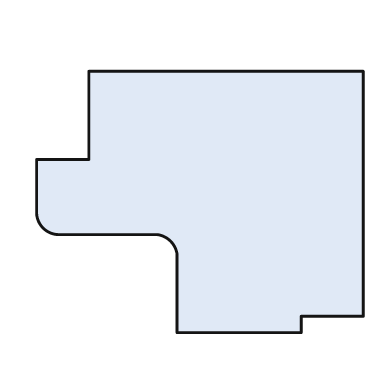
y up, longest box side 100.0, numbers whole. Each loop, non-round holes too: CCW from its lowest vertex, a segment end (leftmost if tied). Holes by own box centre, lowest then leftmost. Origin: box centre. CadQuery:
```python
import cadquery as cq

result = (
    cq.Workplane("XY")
    .moveTo(-7.0, -40.0)
    .lineTo(31.0, -40.0)
    .lineTo(31.0, -35.0)
    .lineTo(50.0, -35.0)
    .lineTo(50.0, 40.0)
    .lineTo(-34.0, 40.0)
    .lineTo(-34.0, 13.0)
    .lineTo(-50.0, 13.0)
    .lineTo(-50.0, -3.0)
    .threePointArc((-48.0, -8.0), (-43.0, -10.0))
    .lineTo(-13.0, -10.0)
    .threePointArc((-9.0, -12.0), (-7.0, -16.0))
    .close()
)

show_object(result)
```